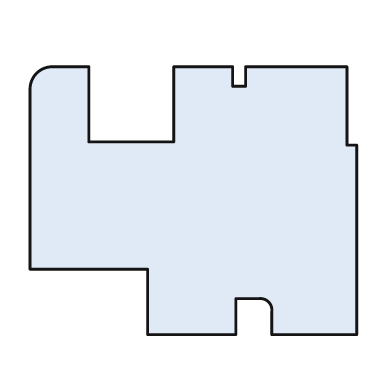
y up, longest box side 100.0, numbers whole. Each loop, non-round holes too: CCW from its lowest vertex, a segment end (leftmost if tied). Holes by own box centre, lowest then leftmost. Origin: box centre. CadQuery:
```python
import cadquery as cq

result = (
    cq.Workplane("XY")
    .moveTo(-14.0, -41.0)
    .lineTo(13.0, -41.0)
    .lineTo(13.0, -30.0)
    .lineTo(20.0, -30.0)
    .threePointArc((23.0, -31.0), (24.0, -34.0))
    .lineTo(24.0, -41.0)
    .lineTo(50.0, -41.0)
    .lineTo(50.0, 17.0)
    .lineTo(47.0, 17.0)
    .lineTo(47.0, 41.0)
    .lineTo(16.0, 41.0)
    .lineTo(16.0, 35.0)
    .lineTo(12.0, 35.0)
    .lineTo(12.0, 41.0)
    .lineTo(-6.0, 41.0)
    .lineTo(-6.0, 18.0)
    .lineTo(-32.0, 18.0)
    .lineTo(-32.0, 41.0)
    .lineTo(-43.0, 41.0)
    .threePointArc((-48.0, 39.0), (-50.0, 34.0))
    .lineTo(-50.0, -21.0)
    .lineTo(-14.0, -21.0)
    .close()
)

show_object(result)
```